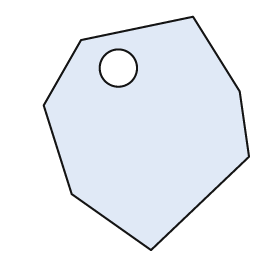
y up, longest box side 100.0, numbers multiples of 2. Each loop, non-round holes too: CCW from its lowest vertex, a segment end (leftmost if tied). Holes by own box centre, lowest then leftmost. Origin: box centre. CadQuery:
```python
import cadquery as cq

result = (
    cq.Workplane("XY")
    .moveTo(2.0, -50.0)
    .lineTo(44.0, -10.0)
    .lineTo(40.0, 18.0)
    .lineTo(20.0, 50.0)
    .lineTo(-28.0, 40.0)
    .lineTo(-44.0, 12.0)
    .lineTo(-32.0, -26.0)
    .close()
    .moveTo(-12.0, 28.0)
    .circle(8.0)
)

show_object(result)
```